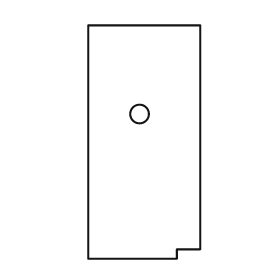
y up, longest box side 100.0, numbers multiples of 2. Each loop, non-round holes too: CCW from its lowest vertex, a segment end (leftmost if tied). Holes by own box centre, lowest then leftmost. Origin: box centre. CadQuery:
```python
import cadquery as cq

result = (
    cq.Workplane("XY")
    .moveTo(-24.0, -50.0)
    .lineTo(14.0, -50.0)
    .lineTo(14.0, -46.0)
    .lineTo(24.0, -46.0)
    .lineTo(24.0, 50.0)
    .lineTo(-24.0, 50.0)
    .close()
    .moveTo(-2.0, 12.0)
    .circle(4.0)
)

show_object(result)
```